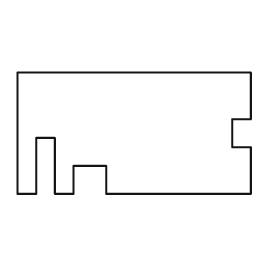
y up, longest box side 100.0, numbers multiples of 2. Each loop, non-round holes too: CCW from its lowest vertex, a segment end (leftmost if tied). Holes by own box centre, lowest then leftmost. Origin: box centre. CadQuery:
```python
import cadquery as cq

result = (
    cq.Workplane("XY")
    .moveTo(-50.0, -26.0)
    .lineTo(-42.0, -26.0)
    .lineTo(-42.0, -2.0)
    .lineTo(-34.0, -2.0)
    .lineTo(-34.0, -26.0)
    .lineTo(-26.0, -26.0)
    .lineTo(-26.0, -14.0)
    .lineTo(-12.0, -14.0)
    .lineTo(-12.0, -26.0)
    .lineTo(50.0, -26.0)
    .lineTo(50.0, -6.0)
    .lineTo(42.0, -6.0)
    .lineTo(42.0, 6.0)
    .lineTo(50.0, 6.0)
    .lineTo(50.0, 26.0)
    .lineTo(-50.0, 26.0)
    .close()
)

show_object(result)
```